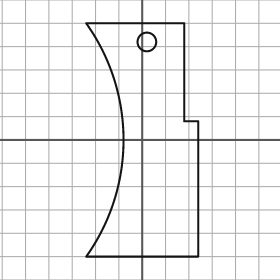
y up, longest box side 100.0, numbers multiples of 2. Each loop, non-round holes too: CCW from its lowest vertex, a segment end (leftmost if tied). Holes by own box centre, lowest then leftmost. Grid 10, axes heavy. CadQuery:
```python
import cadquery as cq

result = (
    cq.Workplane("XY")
    .moveTo(-24.0, -50.0)
    .lineTo(24.0, -50.0)
    .lineTo(24.0, 8.0)
    .lineTo(18.0, 8.0)
    .lineTo(18.0, 50.0)
    .lineTo(-24.0, 50.0)
    .threePointArc((-8.0, 0.0), (-24.0, -50.0))
    .close()
    .moveTo(2.0, 42.0)
    .circle(4.0)
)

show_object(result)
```